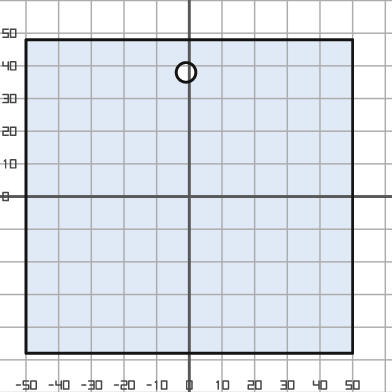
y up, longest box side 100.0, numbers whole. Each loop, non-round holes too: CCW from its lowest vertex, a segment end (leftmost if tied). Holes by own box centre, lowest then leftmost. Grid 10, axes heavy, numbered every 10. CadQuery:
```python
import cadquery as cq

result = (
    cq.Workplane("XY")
    .moveTo(-50.0, -48.0)
    .lineTo(50.0, -48.0)
    .lineTo(50.0, 48.0)
    .lineTo(-50.0, 48.0)
    .close()
    .moveTo(-1.0, 38.0)
    .circle(3.0)
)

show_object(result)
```